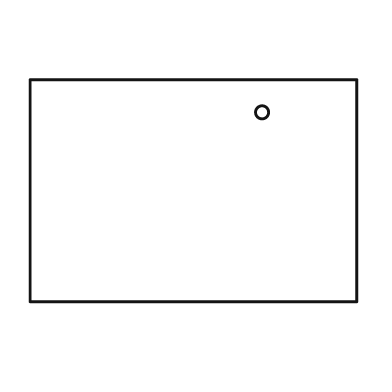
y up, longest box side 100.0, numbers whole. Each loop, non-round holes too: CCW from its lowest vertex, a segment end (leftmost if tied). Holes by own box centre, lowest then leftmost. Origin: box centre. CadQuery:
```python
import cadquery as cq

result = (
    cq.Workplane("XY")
    .moveTo(-50.0, -34.0)
    .lineTo(50.0, -34.0)
    .lineTo(50.0, 34.0)
    .lineTo(-50.0, 34.0)
    .close()
    .moveTo(21.0, 24.0)
    .circle(2.0)
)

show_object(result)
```